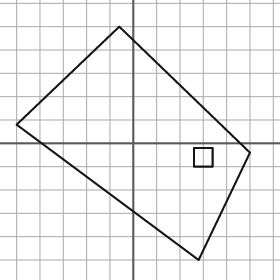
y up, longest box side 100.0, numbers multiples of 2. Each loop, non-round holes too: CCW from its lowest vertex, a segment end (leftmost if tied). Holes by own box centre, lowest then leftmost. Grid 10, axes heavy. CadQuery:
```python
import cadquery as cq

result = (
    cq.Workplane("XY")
    .moveTo(28.0, -50.0)
    .lineTo(50.0, -4.0)
    .lineTo(-6.0, 50.0)
    .lineTo(-50.0, 8.0)
    .close()
    .moveTo(26.0, -10.0)
    .lineTo(34.0, -10.0)
    .lineTo(34.0, -2.0)
    .lineTo(26.0, -2.0)
    .close()
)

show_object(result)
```